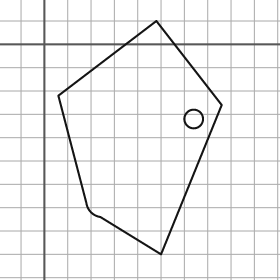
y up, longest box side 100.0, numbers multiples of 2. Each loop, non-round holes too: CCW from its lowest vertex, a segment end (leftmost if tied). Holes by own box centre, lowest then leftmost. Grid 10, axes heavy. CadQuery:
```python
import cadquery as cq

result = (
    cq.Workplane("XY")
    .moveTo(50.0, -90.0)
    .lineTo(76.0, -26.0)
    .lineTo(48.0, 10.0)
    .lineTo(6.0, -22.0)
    .lineTo(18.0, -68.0)
    .threePointArc((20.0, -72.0), (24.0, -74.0))
    .close()
    .moveTo(64.0, -32.0)
    .circle(4.0)
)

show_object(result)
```